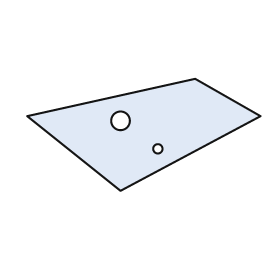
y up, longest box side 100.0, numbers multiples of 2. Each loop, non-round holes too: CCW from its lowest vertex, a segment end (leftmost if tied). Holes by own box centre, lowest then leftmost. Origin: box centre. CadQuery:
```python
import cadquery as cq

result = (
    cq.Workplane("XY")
    .moveTo(-10.0, -24.0)
    .lineTo(50.0, 8.0)
    .lineTo(22.0, 24.0)
    .lineTo(-50.0, 8.0)
    .close()
    .moveTo(6.0, -6.0)
    .circle(2.0)
    .moveTo(-10.0, 6.0)
    .circle(4.0)
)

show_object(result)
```